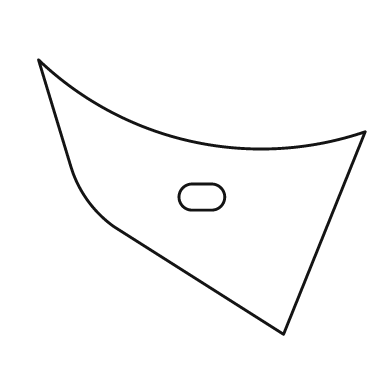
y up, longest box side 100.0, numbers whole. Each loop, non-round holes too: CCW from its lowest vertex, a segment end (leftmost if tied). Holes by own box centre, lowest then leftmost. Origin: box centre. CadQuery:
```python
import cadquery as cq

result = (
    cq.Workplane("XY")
    .moveTo(25.0, -42.0)
    .lineTo(50.0, 20.0)
    .threePointArc((-3.0, 17.0), (-50.0, 42.0))
    .lineTo(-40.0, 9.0)
    .threePointArc((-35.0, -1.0), (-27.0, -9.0))
    .close()
    .moveTo(-3.0, -4.0)
    .lineTo(3.0, -4.0)
    .threePointArc((7.0, 0.0), (3.0, 4.0))
    .lineTo(-3.0, 4.0)
    .threePointArc((-7.0, 0.0), (-3.0, -4.0))
    .close()
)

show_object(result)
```